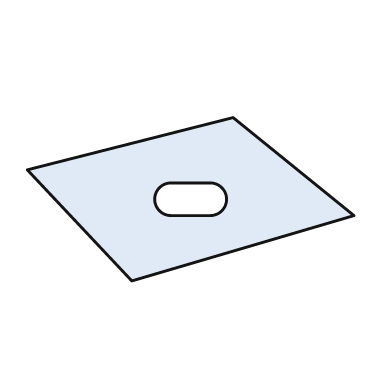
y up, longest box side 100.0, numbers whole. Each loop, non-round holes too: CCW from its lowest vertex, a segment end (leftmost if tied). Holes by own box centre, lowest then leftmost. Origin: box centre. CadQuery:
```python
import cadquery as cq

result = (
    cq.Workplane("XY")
    .moveTo(-18.0, -25.0)
    .lineTo(50.0, -5.0)
    .lineTo(13.0, 25.0)
    .lineTo(-50.0, 9.0)
    .close()
    .moveTo(-6.0, -5.0)
    .lineTo(6.0, -5.0)
    .threePointArc((11.0, 0.0), (6.0, 5.0))
    .lineTo(-6.0, 5.0)
    .threePointArc((-11.0, 0.0), (-6.0, -5.0))
    .close()
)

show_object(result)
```